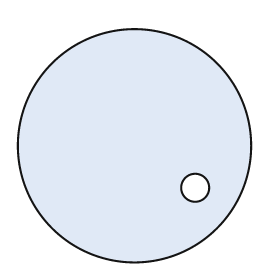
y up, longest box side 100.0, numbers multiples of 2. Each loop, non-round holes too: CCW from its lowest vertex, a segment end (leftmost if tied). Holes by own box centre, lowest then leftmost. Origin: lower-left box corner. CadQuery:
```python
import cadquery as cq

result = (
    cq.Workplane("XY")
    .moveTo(50.0, 50.0)
    .circle(50.0)
    .moveTo(76.0, 32.0)
    .circle(6.0)
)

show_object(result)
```